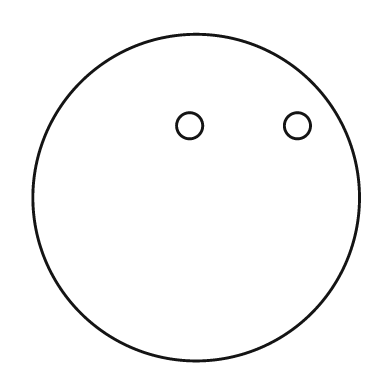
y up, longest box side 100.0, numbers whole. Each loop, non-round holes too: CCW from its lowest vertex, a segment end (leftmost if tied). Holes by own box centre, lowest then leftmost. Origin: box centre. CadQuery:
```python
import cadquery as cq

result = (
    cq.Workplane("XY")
    .moveTo(0.0, 0.0)
    .circle(50.0)
    .moveTo(-2.0, 22.0)
    .circle(4.0)
    .moveTo(31.0, 22.0)
    .circle(4.0)
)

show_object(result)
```